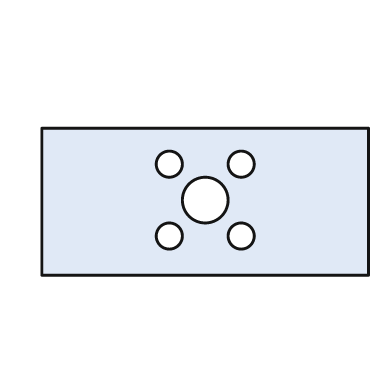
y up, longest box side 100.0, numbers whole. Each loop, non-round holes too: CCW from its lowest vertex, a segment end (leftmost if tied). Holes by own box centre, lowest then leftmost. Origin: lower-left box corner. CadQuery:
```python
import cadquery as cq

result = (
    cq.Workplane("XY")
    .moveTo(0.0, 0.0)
    .lineTo(100.0, 0.0)
    .lineTo(100.0, 45.0)
    .lineTo(0.0, 45.0)
    .close()
    .moveTo(39.0, 12.0)
    .circle(4.0)
    .moveTo(61.0, 12.0)
    .circle(4.0)
    .moveTo(50.0, 23.0)
    .circle(7.0)
    .moveTo(39.0, 34.0)
    .circle(4.0)
    .moveTo(61.0, 34.0)
    .circle(4.0)
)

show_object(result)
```